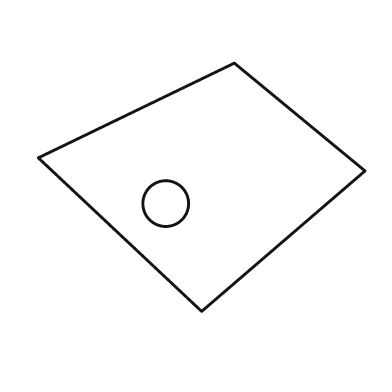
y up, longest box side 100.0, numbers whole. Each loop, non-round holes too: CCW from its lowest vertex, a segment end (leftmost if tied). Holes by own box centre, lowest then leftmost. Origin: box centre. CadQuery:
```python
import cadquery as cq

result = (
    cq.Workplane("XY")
    .moveTo(0.0, -38.0)
    .lineTo(50.0, 5.0)
    .lineTo(10.0, 38.0)
    .lineTo(-50.0, 9.0)
    .close()
    .moveTo(-11.0, -5.0)
    .circle(7.0)
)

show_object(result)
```